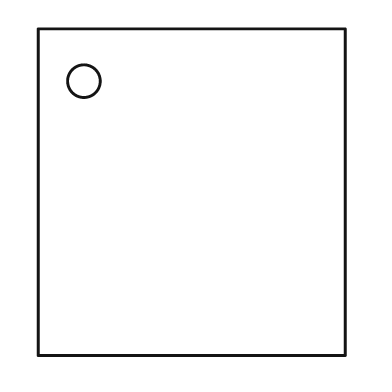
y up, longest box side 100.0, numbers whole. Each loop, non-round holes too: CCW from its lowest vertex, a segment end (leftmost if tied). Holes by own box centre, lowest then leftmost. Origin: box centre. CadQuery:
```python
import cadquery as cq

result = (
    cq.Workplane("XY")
    .moveTo(-47.0, -50.0)
    .lineTo(47.0, -50.0)
    .lineTo(47.0, 50.0)
    .lineTo(-47.0, 50.0)
    .close()
    .moveTo(-33.0, 34.0)
    .circle(5.0)
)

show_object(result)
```